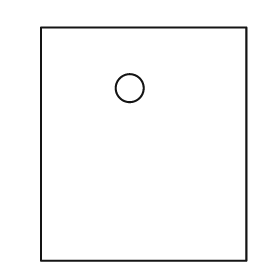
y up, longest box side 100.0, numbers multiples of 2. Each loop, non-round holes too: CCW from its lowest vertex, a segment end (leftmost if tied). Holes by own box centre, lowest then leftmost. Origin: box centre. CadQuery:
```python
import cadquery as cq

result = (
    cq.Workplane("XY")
    .moveTo(-44.0, -50.0)
    .lineTo(44.0, -50.0)
    .lineTo(44.0, 50.0)
    .lineTo(-44.0, 50.0)
    .close()
    .moveTo(-6.0, 24.0)
    .circle(6.0)
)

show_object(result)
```